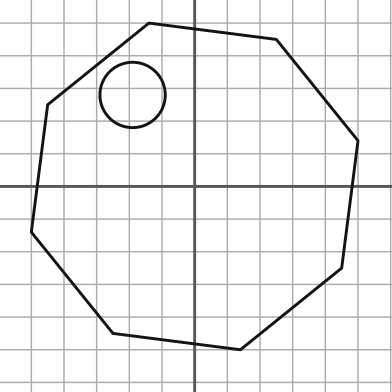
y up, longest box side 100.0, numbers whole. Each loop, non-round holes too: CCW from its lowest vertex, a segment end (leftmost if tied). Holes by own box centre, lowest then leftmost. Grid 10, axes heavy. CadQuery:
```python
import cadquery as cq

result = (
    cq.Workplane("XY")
    .moveTo(14.0, -50.0)
    .lineTo(45.0, -25.0)
    .lineTo(50.0, 14.0)
    .lineTo(25.0, 45.0)
    .lineTo(-14.0, 50.0)
    .lineTo(-45.0, 25.0)
    .lineTo(-50.0, -14.0)
    .lineTo(-25.0, -45.0)
    .close()
    .moveTo(-19.0, 28.0)
    .circle(10.0)
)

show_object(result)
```